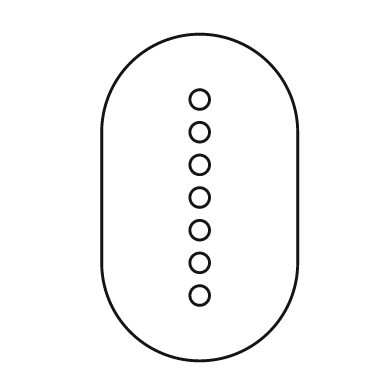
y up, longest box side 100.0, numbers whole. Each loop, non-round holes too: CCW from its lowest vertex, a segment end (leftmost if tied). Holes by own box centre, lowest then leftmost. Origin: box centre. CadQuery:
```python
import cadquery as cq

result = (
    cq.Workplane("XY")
    .moveTo(-30.0, -20.0)
    .threePointArc((0.0, -50.0), (30.0, -20.0))
    .lineTo(30.0, 20.0)
    .threePointArc((0.0, 50.0), (-30.0, 20.0))
    .close()
    .moveTo(0.0, -30.0)
    .circle(3.0)
    .moveTo(0.0, -20.0)
    .circle(3.0)
    .moveTo(0.0, -10.0)
    .circle(3.0)
    .moveTo(0.0, 0.0)
    .circle(3.0)
    .moveTo(0.0, 10.0)
    .circle(3.0)
    .moveTo(0.0, 20.0)
    .circle(3.0)
    .moveTo(0.0, 30.0)
    .circle(3.0)
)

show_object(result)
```